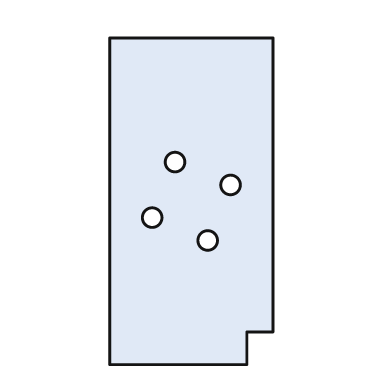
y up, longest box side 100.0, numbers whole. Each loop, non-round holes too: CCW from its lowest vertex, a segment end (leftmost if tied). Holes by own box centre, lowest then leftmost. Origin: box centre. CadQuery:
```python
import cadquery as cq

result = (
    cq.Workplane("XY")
    .moveTo(-25.0, -50.0)
    .lineTo(17.0, -50.0)
    .lineTo(17.0, -40.0)
    .lineTo(25.0, -40.0)
    .lineTo(25.0, 50.0)
    .lineTo(-25.0, 50.0)
    .close()
    .moveTo(5.0, -12.0)
    .circle(3.0)
    .moveTo(-12.0, -5.0)
    .circle(3.0)
    .moveTo(12.0, 5.0)
    .circle(3.0)
    .moveTo(-5.0, 12.0)
    .circle(3.0)
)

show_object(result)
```